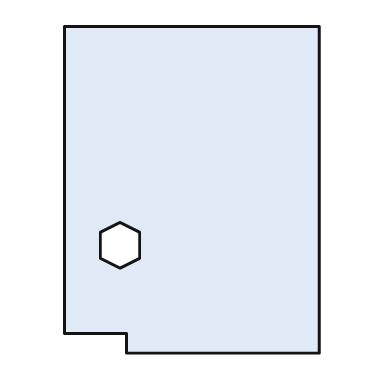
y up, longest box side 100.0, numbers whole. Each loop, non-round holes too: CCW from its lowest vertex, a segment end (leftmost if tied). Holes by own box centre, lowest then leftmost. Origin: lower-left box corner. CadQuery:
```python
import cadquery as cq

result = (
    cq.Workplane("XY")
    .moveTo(19.0, 0.0)
    .lineTo(78.0, 0.0)
    .lineTo(78.0, 100.0)
    .lineTo(0.0, 100.0)
    .lineTo(0.0, 6.0)
    .lineTo(19.0, 6.0)
    .close()
    .moveTo(17.0, 26.0)
    .lineTo(23.0, 29.0)
    .lineTo(23.0, 37.0)
    .lineTo(17.0, 40.0)
    .lineTo(11.0, 37.0)
    .lineTo(11.0, 29.0)
    .close()
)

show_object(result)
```